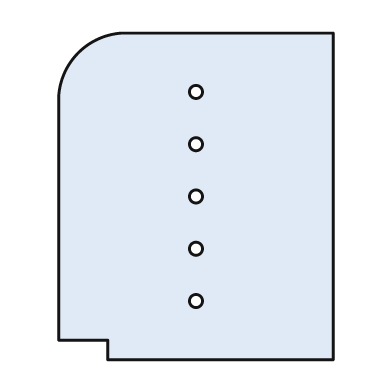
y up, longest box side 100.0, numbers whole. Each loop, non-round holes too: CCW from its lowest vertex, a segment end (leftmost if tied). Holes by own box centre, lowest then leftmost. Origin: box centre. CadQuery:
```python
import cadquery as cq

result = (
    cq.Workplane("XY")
    .moveTo(-27.0, -50.0)
    .lineTo(42.0, -50.0)
    .lineTo(42.0, 50.0)
    .lineTo(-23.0, 50.0)
    .threePointArc((-36.0, 44.0), (-42.0, 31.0))
    .lineTo(-42.0, -44.0)
    .lineTo(-27.0, -44.0)
    .close()
    .moveTo(0.0, -32.0)
    .circle(2.0)
    .moveTo(0.0, -16.0)
    .circle(2.0)
    .moveTo(0.0, 0.0)
    .circle(2.0)
    .moveTo(0.0, 16.0)
    .circle(2.0)
    .moveTo(0.0, 32.0)
    .circle(2.0)
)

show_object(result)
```